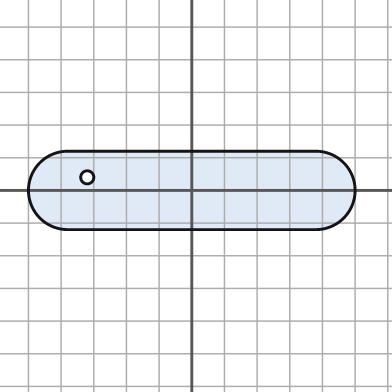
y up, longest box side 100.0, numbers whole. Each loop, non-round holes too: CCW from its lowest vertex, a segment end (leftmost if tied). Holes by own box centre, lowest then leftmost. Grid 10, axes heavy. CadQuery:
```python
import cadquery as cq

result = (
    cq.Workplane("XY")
    .moveTo(-38.0, -12.0)
    .lineTo(38.0, -12.0)
    .threePointArc((50.0, 0.0), (38.0, 12.0))
    .lineTo(-38.0, 12.0)
    .threePointArc((-50.0, 0.0), (-38.0, -12.0))
    .close()
    .moveTo(-32.0, 4.0)
    .circle(2.0)
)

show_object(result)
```